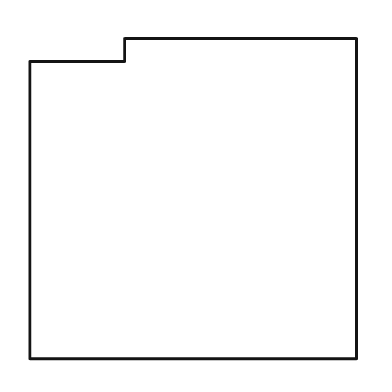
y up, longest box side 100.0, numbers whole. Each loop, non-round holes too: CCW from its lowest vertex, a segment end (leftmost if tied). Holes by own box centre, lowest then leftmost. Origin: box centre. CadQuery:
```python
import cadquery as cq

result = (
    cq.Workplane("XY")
    .moveTo(-50.0, -49.0)
    .lineTo(50.0, -49.0)
    .lineTo(50.0, 49.0)
    .lineTo(-21.0, 49.0)
    .lineTo(-21.0, 42.0)
    .lineTo(-50.0, 42.0)
    .close()
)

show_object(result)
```